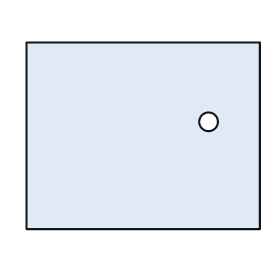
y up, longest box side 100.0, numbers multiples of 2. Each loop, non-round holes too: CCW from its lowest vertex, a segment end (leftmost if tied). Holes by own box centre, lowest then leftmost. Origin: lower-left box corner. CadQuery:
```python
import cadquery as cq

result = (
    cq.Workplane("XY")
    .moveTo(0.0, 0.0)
    .lineTo(100.0, 0.0)
    .lineTo(100.0, 80.0)
    .lineTo(0.0, 80.0)
    .close()
    .moveTo(78.0, 46.0)
    .circle(4.0)
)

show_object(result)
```